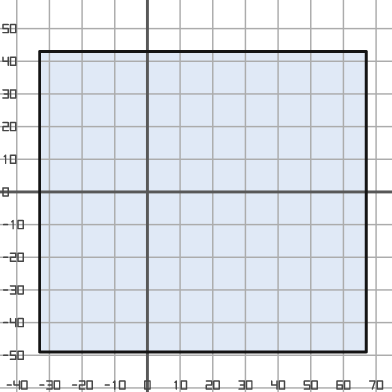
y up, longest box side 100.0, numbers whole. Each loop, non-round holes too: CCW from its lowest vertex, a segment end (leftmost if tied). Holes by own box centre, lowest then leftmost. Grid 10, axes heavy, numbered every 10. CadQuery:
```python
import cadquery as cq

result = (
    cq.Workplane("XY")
    .moveTo(-33.0, -49.0)
    .lineTo(67.0, -49.0)
    .lineTo(67.0, 43.0)
    .lineTo(-33.0, 43.0)
    .close()
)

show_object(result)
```